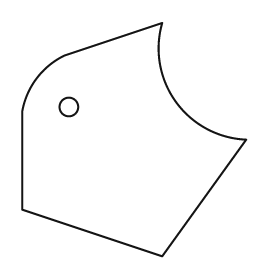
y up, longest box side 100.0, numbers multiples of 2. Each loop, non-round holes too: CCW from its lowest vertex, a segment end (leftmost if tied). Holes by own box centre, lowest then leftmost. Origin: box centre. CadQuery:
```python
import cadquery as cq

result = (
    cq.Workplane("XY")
    .moveTo(12.0, -50.0)
    .lineTo(48.0, 0.0)
    .threePointArc((18.0, 16.0), (12.0, 50.0))
    .lineTo(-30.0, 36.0)
    .threePointArc((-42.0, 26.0), (-48.0, 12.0))
    .lineTo(-48.0, -30.0)
    .close()
    .moveTo(-28.0, 14.0)
    .circle(4.0)
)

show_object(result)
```